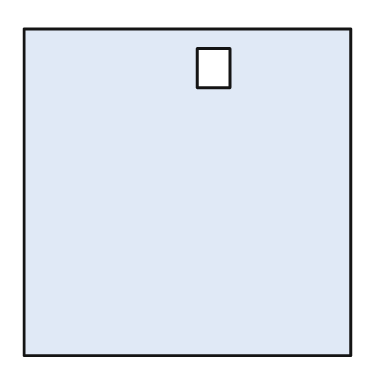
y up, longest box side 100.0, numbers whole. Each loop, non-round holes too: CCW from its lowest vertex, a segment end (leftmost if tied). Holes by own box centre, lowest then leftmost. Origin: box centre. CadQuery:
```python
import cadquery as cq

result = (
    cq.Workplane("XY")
    .moveTo(-50.0, -50.0)
    .lineTo(50.0, -50.0)
    .lineTo(50.0, 50.0)
    .lineTo(-50.0, 50.0)
    .close()
    .moveTo(3.0, 32.0)
    .lineTo(13.0, 32.0)
    .lineTo(13.0, 44.0)
    .lineTo(3.0, 44.0)
    .close()
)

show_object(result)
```